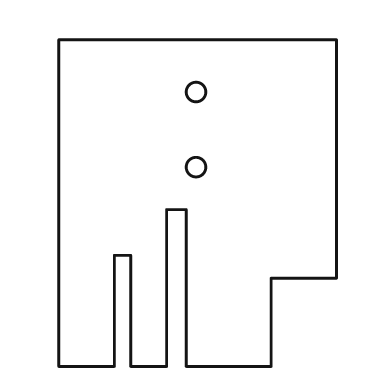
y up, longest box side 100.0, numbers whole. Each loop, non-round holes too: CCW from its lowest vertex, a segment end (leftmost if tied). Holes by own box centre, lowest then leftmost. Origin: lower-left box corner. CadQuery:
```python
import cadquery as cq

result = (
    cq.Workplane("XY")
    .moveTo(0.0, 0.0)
    .lineTo(17.0, 0.0)
    .lineTo(17.0, 34.0)
    .lineTo(22.0, 34.0)
    .lineTo(22.0, 0.0)
    .lineTo(33.0, 0.0)
    .lineTo(33.0, 48.0)
    .lineTo(39.0, 48.0)
    .lineTo(39.0, 0.0)
    .lineTo(65.0, 0.0)
    .lineTo(65.0, 27.0)
    .lineTo(85.0, 27.0)
    .lineTo(85.0, 100.0)
    .lineTo(0.0, 100.0)
    .close()
    .moveTo(42.0, 61.0)
    .circle(3.0)
    .moveTo(42.0, 84.0)
    .circle(3.0)
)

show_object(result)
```